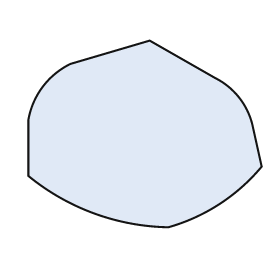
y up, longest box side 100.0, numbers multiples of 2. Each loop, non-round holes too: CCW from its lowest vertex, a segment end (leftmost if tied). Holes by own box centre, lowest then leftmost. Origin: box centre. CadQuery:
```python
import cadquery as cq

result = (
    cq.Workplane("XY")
    .moveTo(10.0, -40.0)
    .threePointArc((32.0, -30.0), (50.0, -14.0))
    .lineTo(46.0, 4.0)
    .threePointArc((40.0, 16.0), (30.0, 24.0))
    .lineTo(2.0, 40.0)
    .lineTo(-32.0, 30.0)
    .threePointArc((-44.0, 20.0), (-50.0, 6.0))
    .lineTo(-50.0, -18.0)
    .threePointArc((-22.0, -34.0), (10.0, -40.0))
    .close()
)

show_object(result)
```